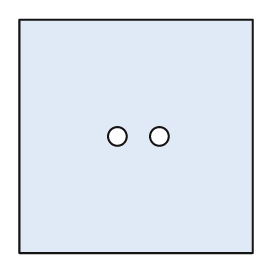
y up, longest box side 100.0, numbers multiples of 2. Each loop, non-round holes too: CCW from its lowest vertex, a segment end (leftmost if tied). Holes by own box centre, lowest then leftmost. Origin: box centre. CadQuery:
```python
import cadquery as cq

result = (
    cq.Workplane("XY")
    .moveTo(-50.0, -50.0)
    .lineTo(50.0, -50.0)
    .lineTo(50.0, 50.0)
    .lineTo(-50.0, 50.0)
    .close()
    .moveTo(-8.0, 0.0)
    .circle(4.0)
    .moveTo(10.0, 0.0)
    .circle(4.0)
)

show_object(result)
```